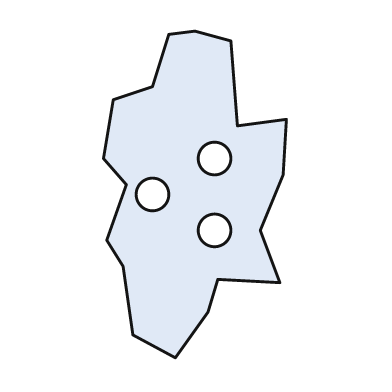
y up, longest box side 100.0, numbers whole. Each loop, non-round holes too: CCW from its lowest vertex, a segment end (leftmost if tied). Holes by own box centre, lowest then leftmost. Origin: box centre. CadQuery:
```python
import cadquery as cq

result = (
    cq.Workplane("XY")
    .moveTo(-6.0, -50.0)
    .lineTo(4.0, -36.0)
    .lineTo(7.0, -26.0)
    .lineTo(26.0, -27.0)
    .lineTo(20.0, -11.0)
    .lineTo(27.0, 6.0)
    .lineTo(28.0, 23.0)
    .lineTo(13.0, 21.0)
    .lineTo(11.0, 47.0)
    .lineTo(0.0, 50.0)
    .lineTo(-8.0, 49.0)
    .lineTo(-13.0, 33.0)
    .lineTo(-25.0, 29.0)
    .lineTo(-28.0, 11.0)
    .lineTo(-21.0, 3.0)
    .lineTo(-27.0, -14.0)
    .lineTo(-22.0, -22.0)
    .lineTo(-19.0, -43.0)
    .close()
    .moveTo(6.0, -11.0)
    .circle(5.0)
    .moveTo(-13.0, 0.0)
    .circle(5.0)
    .moveTo(6.0, 11.0)
    .circle(5.0)
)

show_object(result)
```